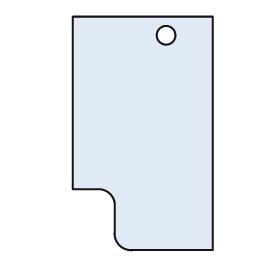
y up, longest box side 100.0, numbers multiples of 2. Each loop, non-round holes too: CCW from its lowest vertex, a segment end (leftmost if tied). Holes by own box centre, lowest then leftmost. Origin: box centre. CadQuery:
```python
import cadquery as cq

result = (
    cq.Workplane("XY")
    .moveTo(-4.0, -50.0)
    .lineTo(30.0, -50.0)
    .lineTo(30.0, 50.0)
    .lineTo(-30.0, 50.0)
    .lineTo(-30.0, -24.0)
    .lineTo(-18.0, -24.0)
    .threePointArc((-14.0, -26.0), (-12.0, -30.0))
    .lineTo(-12.0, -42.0)
    .threePointArc((-10.0, -48.0), (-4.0, -50.0))
    .close()
    .moveTo(10.0, 42.0)
    .circle(4.0)
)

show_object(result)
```